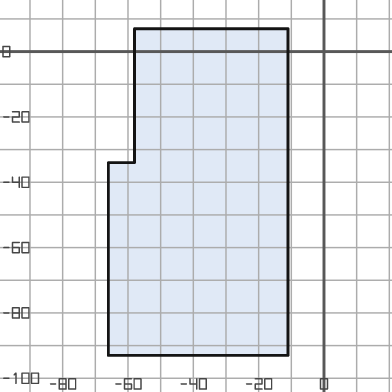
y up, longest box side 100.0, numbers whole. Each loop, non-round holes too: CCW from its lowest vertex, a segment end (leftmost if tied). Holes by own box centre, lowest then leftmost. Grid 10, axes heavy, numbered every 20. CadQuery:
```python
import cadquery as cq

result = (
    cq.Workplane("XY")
    .moveTo(-66.0, -93.0)
    .lineTo(-11.0, -93.0)
    .lineTo(-11.0, 7.0)
    .lineTo(-58.0, 7.0)
    .lineTo(-58.0, -34.0)
    .lineTo(-66.0, -34.0)
    .close()
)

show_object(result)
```